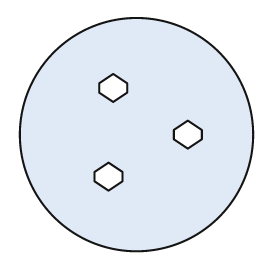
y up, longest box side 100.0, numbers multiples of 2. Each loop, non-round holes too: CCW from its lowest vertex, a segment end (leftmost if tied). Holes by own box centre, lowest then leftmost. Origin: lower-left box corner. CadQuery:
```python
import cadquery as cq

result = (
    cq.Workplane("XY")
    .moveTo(50.0, 50.0)
    .circle(50.0)
    .moveTo(38.0, 26.0)
    .lineTo(44.0, 30.0)
    .lineTo(44.0, 34.0)
    .lineTo(38.0, 38.0)
    .lineTo(32.0, 34.0)
    .lineTo(32.0, 30.0)
    .close()
    .moveTo(72.0, 44.0)
    .lineTo(78.0, 48.0)
    .lineTo(78.0, 52.0)
    .lineTo(72.0, 56.0)
    .lineTo(66.0, 52.0)
    .lineTo(66.0, 48.0)
    .close()
    .moveTo(40.0, 64.0)
    .lineTo(46.0, 68.0)
    .lineTo(46.0, 72.0)
    .lineTo(40.0, 76.0)
    .lineTo(34.0, 72.0)
    .lineTo(34.0, 68.0)
    .close()
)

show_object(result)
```